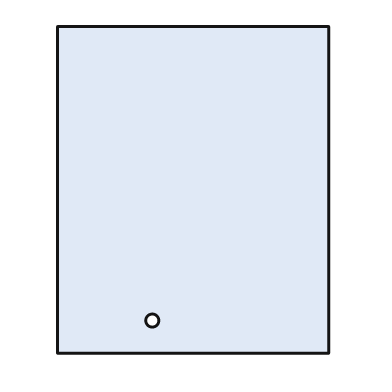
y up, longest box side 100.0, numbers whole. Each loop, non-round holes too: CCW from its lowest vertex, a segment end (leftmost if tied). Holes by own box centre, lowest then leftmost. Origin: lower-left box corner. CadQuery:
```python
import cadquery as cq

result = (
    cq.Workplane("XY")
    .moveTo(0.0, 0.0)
    .lineTo(83.0, 0.0)
    .lineTo(83.0, 100.0)
    .lineTo(0.0, 100.0)
    .close()
    .moveTo(29.0, 10.0)
    .circle(2.0)
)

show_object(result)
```